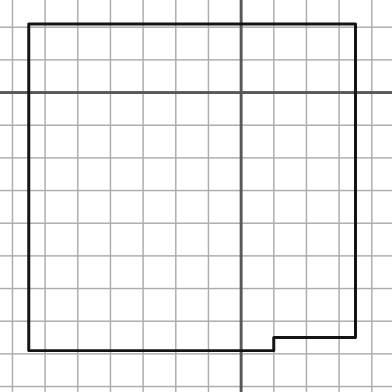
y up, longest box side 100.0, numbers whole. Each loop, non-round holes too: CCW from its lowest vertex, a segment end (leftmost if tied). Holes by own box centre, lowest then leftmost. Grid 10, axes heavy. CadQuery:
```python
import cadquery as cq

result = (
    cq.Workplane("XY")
    .moveTo(-65.0, -79.0)
    .lineTo(10.0, -79.0)
    .lineTo(10.0, -75.0)
    .lineTo(35.0, -75.0)
    .lineTo(35.0, 21.0)
    .lineTo(-65.0, 21.0)
    .close()
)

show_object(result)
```